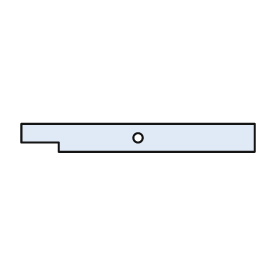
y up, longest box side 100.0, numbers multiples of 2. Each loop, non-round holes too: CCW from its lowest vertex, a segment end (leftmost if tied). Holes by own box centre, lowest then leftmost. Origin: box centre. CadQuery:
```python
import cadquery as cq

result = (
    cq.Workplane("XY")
    .moveTo(-34.0, -6.0)
    .lineTo(50.0, -6.0)
    .lineTo(50.0, 6.0)
    .lineTo(-50.0, 6.0)
    .lineTo(-50.0, -2.0)
    .lineTo(-34.0, -2.0)
    .close()
    .moveTo(0.0, 0.0)
    .circle(2.0)
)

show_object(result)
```